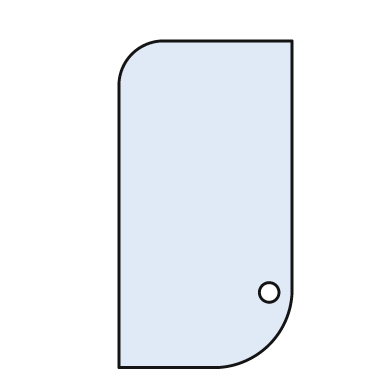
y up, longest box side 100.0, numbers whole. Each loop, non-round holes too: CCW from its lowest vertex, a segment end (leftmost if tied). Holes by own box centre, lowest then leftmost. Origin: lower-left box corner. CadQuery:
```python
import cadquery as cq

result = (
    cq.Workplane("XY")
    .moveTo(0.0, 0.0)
    .lineTo(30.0, 0.0)
    .threePointArc((46.0, 7.0), (53.0, 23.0))
    .lineTo(53.0, 100.0)
    .lineTo(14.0, 100.0)
    .threePointArc((4.0, 96.0), (0.0, 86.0))
    .close()
    .moveTo(46.0, 23.0)
    .circle(3.0)
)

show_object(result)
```